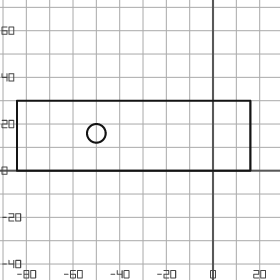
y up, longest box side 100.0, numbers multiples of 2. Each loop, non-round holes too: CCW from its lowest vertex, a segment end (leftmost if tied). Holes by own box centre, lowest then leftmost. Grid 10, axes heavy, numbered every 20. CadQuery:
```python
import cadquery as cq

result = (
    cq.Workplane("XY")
    .moveTo(-84.0, 0.0)
    .lineTo(16.0, 0.0)
    .lineTo(16.0, 30.0)
    .lineTo(-84.0, 30.0)
    .close()
    .moveTo(-50.0, 16.0)
    .circle(4.0)
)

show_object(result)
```